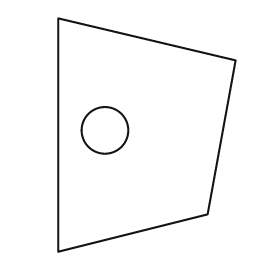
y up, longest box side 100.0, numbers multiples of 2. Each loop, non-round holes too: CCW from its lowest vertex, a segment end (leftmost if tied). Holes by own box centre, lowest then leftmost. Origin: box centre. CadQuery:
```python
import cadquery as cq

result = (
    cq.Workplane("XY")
    .moveTo(-38.0, -50.0)
    .lineTo(26.0, -34.0)
    .lineTo(38.0, 32.0)
    .lineTo(-38.0, 50.0)
    .close()
    .moveTo(-18.0, 2.0)
    .circle(10.0)
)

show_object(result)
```